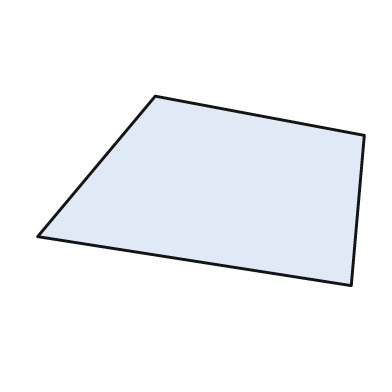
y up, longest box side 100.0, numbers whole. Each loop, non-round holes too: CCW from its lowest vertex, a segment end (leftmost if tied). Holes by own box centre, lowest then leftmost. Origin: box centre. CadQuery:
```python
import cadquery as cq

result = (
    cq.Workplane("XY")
    .moveTo(46.0, -29.0)
    .lineTo(50.0, 17.0)
    .lineTo(-14.0, 29.0)
    .lineTo(-50.0, -14.0)
    .close()
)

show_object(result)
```